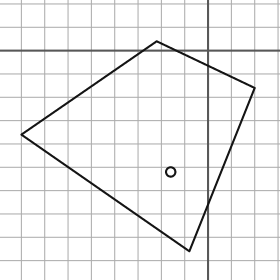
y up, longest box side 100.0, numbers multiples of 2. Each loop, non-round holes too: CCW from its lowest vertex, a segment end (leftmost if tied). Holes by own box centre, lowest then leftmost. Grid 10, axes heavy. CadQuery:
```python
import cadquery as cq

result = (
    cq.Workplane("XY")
    .moveTo(-8.0, -86.0)
    .lineTo(20.0, -16.0)
    .lineTo(-22.0, 4.0)
    .lineTo(-80.0, -36.0)
    .close()
    .moveTo(-16.0, -52.0)
    .circle(2.0)
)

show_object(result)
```